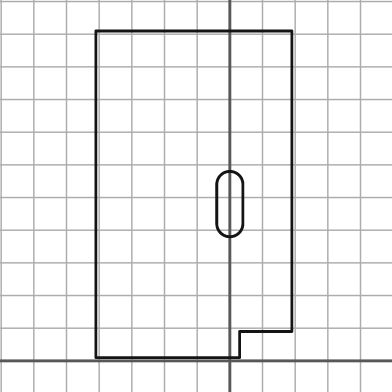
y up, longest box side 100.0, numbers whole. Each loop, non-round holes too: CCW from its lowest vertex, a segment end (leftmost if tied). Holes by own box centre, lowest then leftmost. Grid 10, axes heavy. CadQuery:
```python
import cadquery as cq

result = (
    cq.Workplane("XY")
    .moveTo(-41.0, 1.0)
    .lineTo(3.0, 1.0)
    .lineTo(3.0, 9.0)
    .lineTo(19.0, 9.0)
    .lineTo(19.0, 101.0)
    .lineTo(-41.0, 101.0)
    .close()
    .moveTo(-4.0, 42.0)
    .threePointArc((0.0, 38.0), (4.0, 42.0))
    .lineTo(4.0, 54.0)
    .threePointArc((0.0, 58.0), (-4.0, 54.0))
    .close()
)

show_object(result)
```